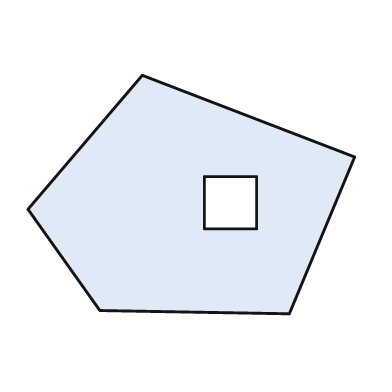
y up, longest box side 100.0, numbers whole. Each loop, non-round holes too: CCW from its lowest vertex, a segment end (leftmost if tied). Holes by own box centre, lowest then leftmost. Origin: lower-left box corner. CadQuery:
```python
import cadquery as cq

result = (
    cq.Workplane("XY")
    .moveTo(80.0, 0.0)
    .lineTo(100.0, 48.0)
    .lineTo(35.0, 73.0)
    .lineTo(0.0, 32.0)
    .lineTo(22.0, 1.0)
    .close()
    .moveTo(54.0, 26.0)
    .lineTo(70.0, 26.0)
    .lineTo(70.0, 42.0)
    .lineTo(54.0, 42.0)
    .close()
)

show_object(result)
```